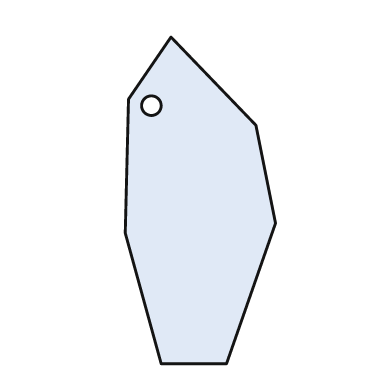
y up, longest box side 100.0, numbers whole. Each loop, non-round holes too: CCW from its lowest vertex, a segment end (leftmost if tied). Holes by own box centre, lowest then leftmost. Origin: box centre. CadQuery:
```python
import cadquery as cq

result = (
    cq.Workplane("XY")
    .moveTo(-12.0, -50.0)
    .lineTo(8.0, -50.0)
    .lineTo(23.0, -7.0)
    .lineTo(17.0, 23.0)
    .lineTo(-9.0, 50.0)
    .lineTo(-22.0, 31.0)
    .lineTo(-23.0, -10.0)
    .close()
    .moveTo(-15.0, 29.0)
    .circle(3.0)
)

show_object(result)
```